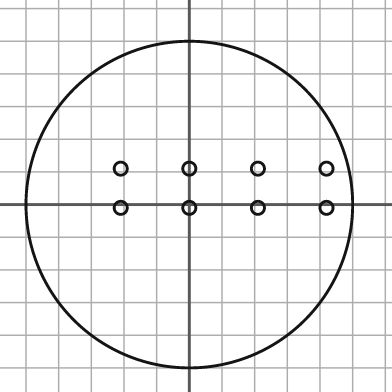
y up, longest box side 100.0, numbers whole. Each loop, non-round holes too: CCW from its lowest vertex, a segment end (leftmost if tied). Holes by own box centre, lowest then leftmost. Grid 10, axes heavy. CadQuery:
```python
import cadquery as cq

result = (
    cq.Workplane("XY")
    .moveTo(0.0, 0.0)
    .circle(50.0)
    .moveTo(-21.0, -1.0)
    .circle(2.0)
    .moveTo(0.0, -1.0)
    .circle(2.0)
    .moveTo(21.0, -1.0)
    .circle(2.0)
    .moveTo(42.0, -1.0)
    .circle(2.0)
    .moveTo(-21.0, 11.0)
    .circle(2.0)
    .moveTo(0.0, 11.0)
    .circle(2.0)
    .moveTo(21.0, 11.0)
    .circle(2.0)
    .moveTo(42.0, 11.0)
    .circle(2.0)
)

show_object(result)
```